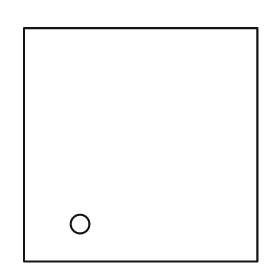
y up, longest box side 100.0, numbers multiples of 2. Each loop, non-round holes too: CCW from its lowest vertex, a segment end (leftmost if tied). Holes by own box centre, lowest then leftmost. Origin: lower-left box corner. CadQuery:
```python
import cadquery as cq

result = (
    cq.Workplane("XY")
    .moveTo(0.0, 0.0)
    .lineTo(100.0, 0.0)
    .lineTo(100.0, 100.0)
    .lineTo(0.0, 100.0)
    .close()
    .moveTo(24.0, 16.0)
    .circle(4.0)
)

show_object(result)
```